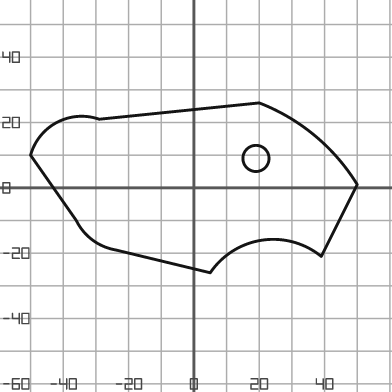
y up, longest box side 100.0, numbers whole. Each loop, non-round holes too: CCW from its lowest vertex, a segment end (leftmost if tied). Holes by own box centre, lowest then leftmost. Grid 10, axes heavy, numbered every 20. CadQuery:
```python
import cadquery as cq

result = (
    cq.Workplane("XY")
    .moveTo(5.0, -26.0)
    .threePointArc((21.0, -16.0), (39.0, -21.0))
    .lineTo(50.0, 1.0)
    .threePointArc((37.0, 16.0), (20.0, 26.0))
    .lineTo(-29.0, 21.0)
    .threePointArc((-42.0, 20.0), (-50.0, 10.0))
    .lineTo(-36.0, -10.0)
    .threePointArc((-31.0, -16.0), (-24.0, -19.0))
    .close()
    .moveTo(19.0, 9.0)
    .circle(4.0)
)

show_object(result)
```